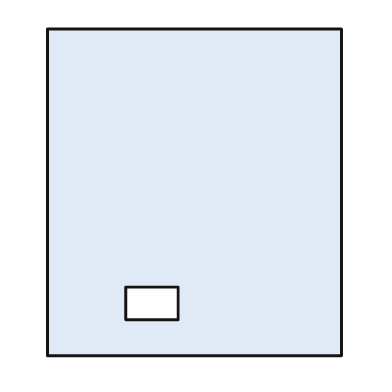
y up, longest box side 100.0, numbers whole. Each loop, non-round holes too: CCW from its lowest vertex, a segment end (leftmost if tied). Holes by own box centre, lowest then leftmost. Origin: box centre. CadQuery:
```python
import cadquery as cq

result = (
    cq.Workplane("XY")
    .moveTo(-45.0, -50.0)
    .lineTo(45.0, -50.0)
    .lineTo(45.0, 50.0)
    .lineTo(-45.0, 50.0)
    .close()
    .moveTo(-21.0, -39.0)
    .lineTo(-5.0, -39.0)
    .lineTo(-5.0, -29.0)
    .lineTo(-21.0, -29.0)
    .close()
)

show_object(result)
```